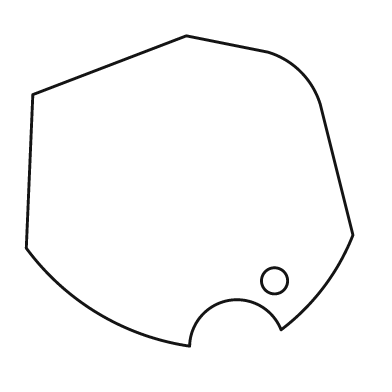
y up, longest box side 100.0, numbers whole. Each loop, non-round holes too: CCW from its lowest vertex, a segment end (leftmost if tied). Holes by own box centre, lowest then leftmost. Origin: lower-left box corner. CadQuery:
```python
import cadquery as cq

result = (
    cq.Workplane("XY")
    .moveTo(50.0, 0.0)
    .threePointArc((62.0, 14.0), (78.0, 5.0))
    .threePointArc((91.0, 18.0), (100.0, 34.0))
    .lineTo(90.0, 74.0)
    .threePointArc((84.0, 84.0), (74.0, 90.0))
    .lineTo(49.0, 95.0)
    .lineTo(2.0, 77.0)
    .lineTo(0.0, 30.0)
    .threePointArc((22.0, 10.0), (50.0, 0.0))
    .close()
    .moveTo(76.0, 20.0)
    .circle(4.0)
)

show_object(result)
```